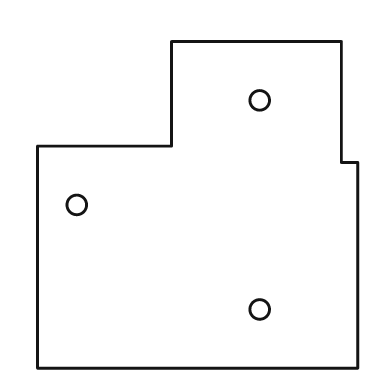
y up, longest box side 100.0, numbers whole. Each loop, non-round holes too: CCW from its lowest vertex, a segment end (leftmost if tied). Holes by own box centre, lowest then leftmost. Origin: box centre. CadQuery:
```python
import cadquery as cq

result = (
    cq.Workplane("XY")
    .moveTo(-49.0, -50.0)
    .lineTo(49.0, -50.0)
    .lineTo(49.0, 13.0)
    .lineTo(44.0, 13.0)
    .lineTo(44.0, 50.0)
    .lineTo(-8.0, 50.0)
    .lineTo(-8.0, 18.0)
    .lineTo(-49.0, 18.0)
    .close()
    .moveTo(19.0, -32.0)
    .circle(3.0)
    .moveTo(-37.0, 0.0)
    .circle(3.0)
    .moveTo(19.0, 32.0)
    .circle(3.0)
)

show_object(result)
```